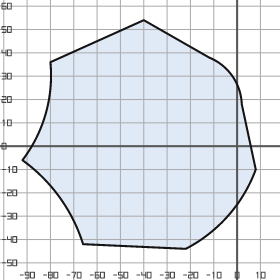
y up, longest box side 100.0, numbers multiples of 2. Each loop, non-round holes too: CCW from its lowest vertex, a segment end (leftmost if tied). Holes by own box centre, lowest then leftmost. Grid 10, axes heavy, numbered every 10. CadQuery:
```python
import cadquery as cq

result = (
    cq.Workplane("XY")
    .moveTo(-22.0, -44.0)
    .threePointArc((-4.0, -30.0), (8.0, -10.0))
    .lineTo(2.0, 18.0)
    .threePointArc((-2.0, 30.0), (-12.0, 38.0))
    .lineTo(-40.0, 54.0)
    .lineTo(-80.0, 36.0)
    .threePointArc((-82.0, 14.0), (-92.0, -6.0))
    .threePointArc((-76.0, -22.0), (-66.0, -42.0))
    .close()
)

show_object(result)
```